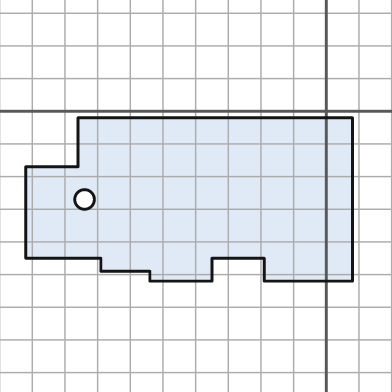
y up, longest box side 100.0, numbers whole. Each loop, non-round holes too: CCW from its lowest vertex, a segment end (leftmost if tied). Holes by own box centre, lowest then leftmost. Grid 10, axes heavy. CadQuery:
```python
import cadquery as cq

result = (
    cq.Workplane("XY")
    .moveTo(-54.0, -52.0)
    .lineTo(-35.0, -52.0)
    .lineTo(-35.0, -45.0)
    .lineTo(-19.0, -45.0)
    .lineTo(-19.0, -52.0)
    .lineTo(8.0, -52.0)
    .lineTo(8.0, -2.0)
    .lineTo(-76.0, -2.0)
    .lineTo(-76.0, -17.0)
    .lineTo(-92.0, -17.0)
    .lineTo(-92.0, -45.0)
    .lineTo(-69.0, -45.0)
    .lineTo(-69.0, -49.0)
    .lineTo(-54.0, -49.0)
    .close()
    .moveTo(-74.0, -27.0)
    .circle(3.0)
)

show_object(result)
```